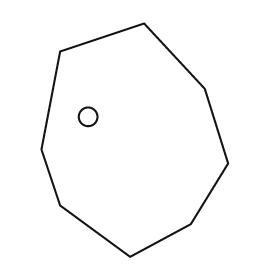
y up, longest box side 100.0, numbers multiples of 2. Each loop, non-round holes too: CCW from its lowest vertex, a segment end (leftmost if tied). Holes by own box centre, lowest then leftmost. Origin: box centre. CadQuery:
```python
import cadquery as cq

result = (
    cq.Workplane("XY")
    .moveTo(-2.0, -50.0)
    .lineTo(24.0, -36.0)
    .lineTo(40.0, -10.0)
    .lineTo(30.0, 22.0)
    .lineTo(4.0, 50.0)
    .lineTo(-32.0, 38.0)
    .lineTo(-40.0, -4.0)
    .lineTo(-32.0, -28.0)
    .close()
    .moveTo(-20.0, 10.0)
    .circle(4.0)
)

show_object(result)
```